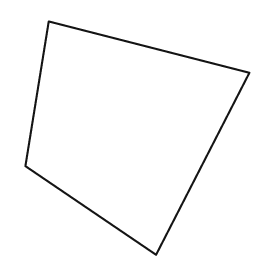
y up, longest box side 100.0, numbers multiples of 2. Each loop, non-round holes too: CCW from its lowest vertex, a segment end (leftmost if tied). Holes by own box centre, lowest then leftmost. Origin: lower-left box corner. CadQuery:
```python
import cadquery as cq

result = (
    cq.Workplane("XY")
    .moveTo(56.0, 0.0)
    .lineTo(96.0, 78.0)
    .lineTo(10.0, 100.0)
    .lineTo(0.0, 38.0)
    .close()
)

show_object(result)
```